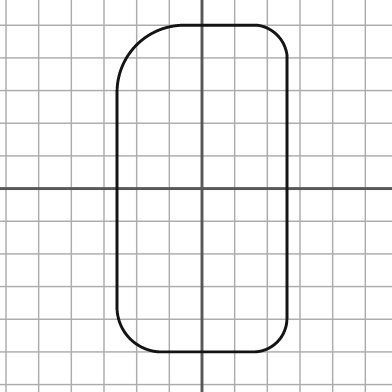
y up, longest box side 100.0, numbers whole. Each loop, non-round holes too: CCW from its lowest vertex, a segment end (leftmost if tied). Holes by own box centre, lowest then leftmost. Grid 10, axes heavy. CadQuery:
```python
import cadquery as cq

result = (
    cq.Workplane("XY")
    .moveTo(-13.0, -50.0)
    .lineTo(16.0, -50.0)
    .threePointArc((23.0, -47.0), (26.0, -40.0))
    .lineTo(26.0, 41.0)
    .threePointArc((23.0, 47.0), (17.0, 50.0))
    .lineTo(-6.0, 50.0)
    .threePointArc((-20.0, 44.0), (-26.0, 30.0))
    .lineTo(-26.0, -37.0)
    .threePointArc((-22.0, -46.0), (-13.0, -50.0))
    .close()
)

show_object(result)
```